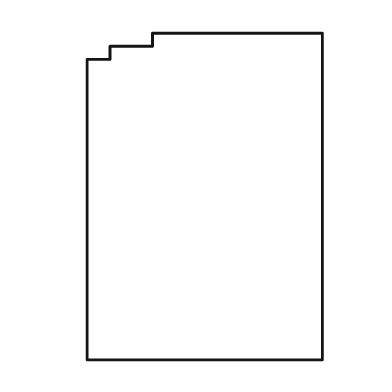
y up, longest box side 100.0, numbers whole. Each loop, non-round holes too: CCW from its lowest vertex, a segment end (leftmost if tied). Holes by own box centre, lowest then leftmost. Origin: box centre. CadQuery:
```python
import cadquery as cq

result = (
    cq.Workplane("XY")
    .moveTo(-36.0, -50.0)
    .lineTo(36.0, -50.0)
    .lineTo(36.0, 50.0)
    .lineTo(-16.0, 50.0)
    .lineTo(-16.0, 46.0)
    .lineTo(-29.0, 46.0)
    .lineTo(-29.0, 42.0)
    .lineTo(-36.0, 42.0)
    .close()
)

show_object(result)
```